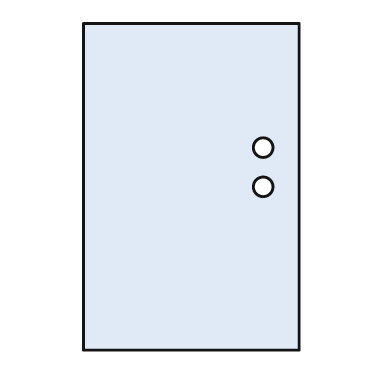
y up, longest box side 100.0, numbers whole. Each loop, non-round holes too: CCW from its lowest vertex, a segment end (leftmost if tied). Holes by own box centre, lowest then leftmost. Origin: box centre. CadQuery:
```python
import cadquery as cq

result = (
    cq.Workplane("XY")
    .moveTo(-33.0, -50.0)
    .lineTo(33.0, -50.0)
    .lineTo(33.0, 50.0)
    .lineTo(-33.0, 50.0)
    .close()
    .moveTo(22.0, 0.0)
    .circle(3.0)
    .moveTo(22.0, 12.0)
    .circle(3.0)
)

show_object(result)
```